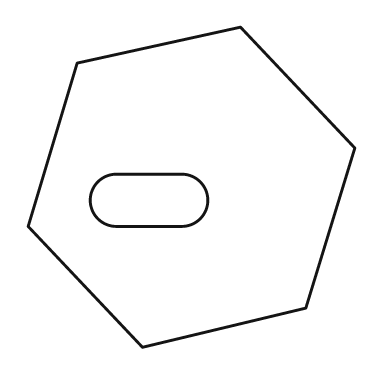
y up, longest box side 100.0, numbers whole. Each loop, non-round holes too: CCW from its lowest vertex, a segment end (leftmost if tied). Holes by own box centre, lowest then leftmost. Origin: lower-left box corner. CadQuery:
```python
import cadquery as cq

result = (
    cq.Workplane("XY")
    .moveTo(35.0, 0.0)
    .lineTo(85.0, 12.0)
    .lineTo(100.0, 61.0)
    .lineTo(65.0, 98.0)
    .lineTo(15.0, 87.0)
    .lineTo(0.0, 37.0)
    .close()
    .moveTo(27.0, 37.0)
    .lineTo(47.0, 37.0)
    .threePointArc((55.0, 45.0), (47.0, 53.0))
    .lineTo(27.0, 53.0)
    .threePointArc((19.0, 45.0), (27.0, 37.0))
    .close()
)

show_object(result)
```